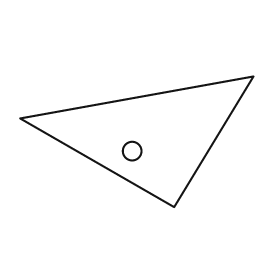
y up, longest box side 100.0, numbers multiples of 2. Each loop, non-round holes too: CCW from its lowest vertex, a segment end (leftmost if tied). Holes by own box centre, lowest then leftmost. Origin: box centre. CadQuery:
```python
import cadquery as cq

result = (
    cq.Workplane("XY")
    .moveTo(16.0, -28.0)
    .lineTo(50.0, 28.0)
    .lineTo(-50.0, 10.0)
    .close()
    .moveTo(-2.0, -4.0)
    .circle(4.0)
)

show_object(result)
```